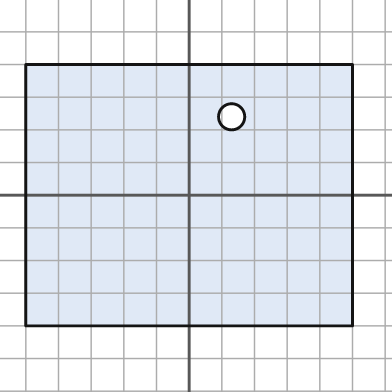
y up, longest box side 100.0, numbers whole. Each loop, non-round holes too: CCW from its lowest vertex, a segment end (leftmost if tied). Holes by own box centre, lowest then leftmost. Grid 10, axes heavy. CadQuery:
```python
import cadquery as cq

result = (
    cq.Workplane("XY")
    .moveTo(-50.0, -40.0)
    .lineTo(50.0, -40.0)
    .lineTo(50.0, 40.0)
    .lineTo(-50.0, 40.0)
    .close()
    .moveTo(13.0, 24.0)
    .circle(4.0)
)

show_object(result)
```